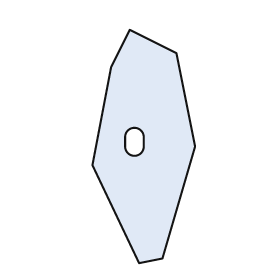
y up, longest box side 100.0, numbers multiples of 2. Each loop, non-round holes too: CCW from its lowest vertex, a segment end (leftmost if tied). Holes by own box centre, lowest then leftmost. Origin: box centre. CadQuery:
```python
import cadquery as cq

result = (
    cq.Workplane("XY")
    .moveTo(-2.0, -50.0)
    .lineTo(8.0, -48.0)
    .lineTo(22.0, 0.0)
    .lineTo(14.0, 40.0)
    .lineTo(-6.0, 50.0)
    .lineTo(-14.0, 34.0)
    .lineTo(-22.0, -8.0)
    .close()
    .moveTo(-8.0, 0.0)
    .threePointArc((-4.0, -4.0), (0.0, 0.0))
    .lineTo(0.0, 4.0)
    .threePointArc((-4.0, 8.0), (-8.0, 4.0))
    .close()
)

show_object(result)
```